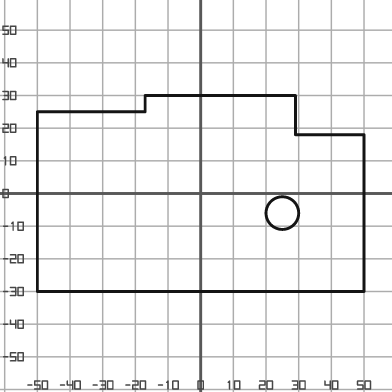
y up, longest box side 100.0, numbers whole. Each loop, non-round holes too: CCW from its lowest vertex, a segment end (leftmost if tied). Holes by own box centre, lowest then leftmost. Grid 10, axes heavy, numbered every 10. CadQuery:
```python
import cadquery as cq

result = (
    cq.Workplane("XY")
    .moveTo(-50.0, -30.0)
    .lineTo(50.0, -30.0)
    .lineTo(50.0, 18.0)
    .lineTo(29.0, 18.0)
    .lineTo(29.0, 30.0)
    .lineTo(-17.0, 30.0)
    .lineTo(-17.0, 25.0)
    .lineTo(-50.0, 25.0)
    .close()
    .moveTo(25.0, -6.0)
    .circle(5.0)
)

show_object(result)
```